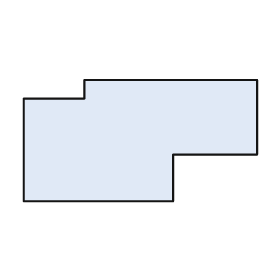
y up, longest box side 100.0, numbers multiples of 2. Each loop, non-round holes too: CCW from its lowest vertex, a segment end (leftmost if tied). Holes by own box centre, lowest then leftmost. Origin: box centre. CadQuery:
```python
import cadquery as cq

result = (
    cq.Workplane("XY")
    .moveTo(-50.0, -26.0)
    .lineTo(14.0, -26.0)
    .lineTo(14.0, -6.0)
    .lineTo(50.0, -6.0)
    .lineTo(50.0, 26.0)
    .lineTo(-24.0, 26.0)
    .lineTo(-24.0, 18.0)
    .lineTo(-50.0, 18.0)
    .close()
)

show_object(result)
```